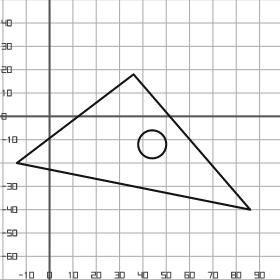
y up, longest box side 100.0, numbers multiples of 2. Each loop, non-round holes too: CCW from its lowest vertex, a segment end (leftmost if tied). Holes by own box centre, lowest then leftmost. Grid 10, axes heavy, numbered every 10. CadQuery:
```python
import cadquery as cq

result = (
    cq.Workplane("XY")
    .moveTo(86.0, -40.0)
    .lineTo(36.0, 18.0)
    .lineTo(-14.0, -20.0)
    .close()
    .moveTo(44.0, -12.0)
    .circle(6.0)
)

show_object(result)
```